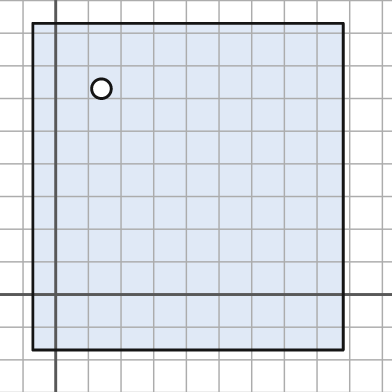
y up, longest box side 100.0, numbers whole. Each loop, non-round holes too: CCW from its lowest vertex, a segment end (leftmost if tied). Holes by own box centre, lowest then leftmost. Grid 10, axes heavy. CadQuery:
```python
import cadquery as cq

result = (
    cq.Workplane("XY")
    .moveTo(-7.0, -17.0)
    .lineTo(88.0, -17.0)
    .lineTo(88.0, 83.0)
    .lineTo(-7.0, 83.0)
    .close()
    .moveTo(14.0, 63.0)
    .circle(3.0)
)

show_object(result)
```